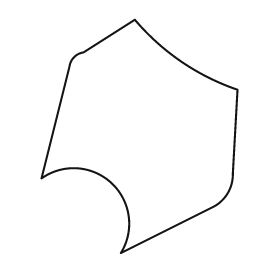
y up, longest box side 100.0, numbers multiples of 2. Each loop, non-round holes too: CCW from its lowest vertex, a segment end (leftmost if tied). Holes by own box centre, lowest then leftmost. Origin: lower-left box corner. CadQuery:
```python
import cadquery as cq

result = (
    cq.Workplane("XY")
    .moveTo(34.0, 0.0)
    .lineTo(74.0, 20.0)
    .threePointArc((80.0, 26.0), (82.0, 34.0))
    .lineTo(84.0, 70.0)
    .threePointArc((60.0, 82.0), (40.0, 100.0))
    .lineTo(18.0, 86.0)
    .threePointArc((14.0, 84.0), (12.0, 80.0))
    .lineTo(0.0, 32.0)
    .threePointArc((30.0, 30.0), (34.0, 0.0))
    .close()
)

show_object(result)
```